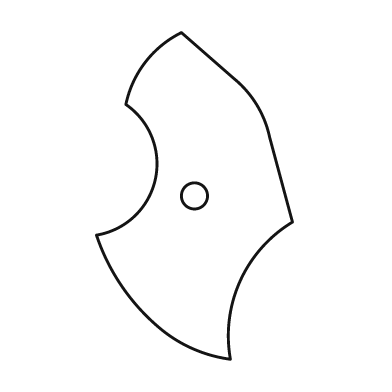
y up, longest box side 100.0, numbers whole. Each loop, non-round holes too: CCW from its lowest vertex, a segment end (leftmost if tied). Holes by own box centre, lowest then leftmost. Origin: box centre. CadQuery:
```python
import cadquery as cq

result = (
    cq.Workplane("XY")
    .moveTo(11.0, -50.0)
    .threePointArc((14.0, -26.0), (30.0, -8.0))
    .lineTo(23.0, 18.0)
    .threePointArc((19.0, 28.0), (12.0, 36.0))
    .lineTo(-4.0, 50.0)
    .threePointArc((-15.0, 41.0), (-21.0, 28.0))
    .threePointArc((-12.0, 5.0), (-30.0, -12.0))
    .threePointArc((-22.0, -28.0), (-10.0, -41.0))
    .threePointArc((0.0, -47.0), (11.0, -50.0))
    .close()
    .moveTo(0.0, 0.0)
    .circle(4.0)
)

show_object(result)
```